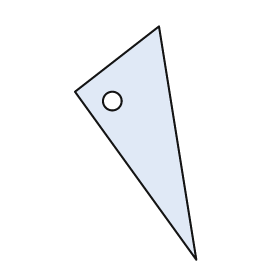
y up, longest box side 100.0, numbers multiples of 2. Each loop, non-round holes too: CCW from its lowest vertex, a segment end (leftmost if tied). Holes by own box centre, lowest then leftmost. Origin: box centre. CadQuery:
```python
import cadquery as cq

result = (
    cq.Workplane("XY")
    .moveTo(26.0, -50.0)
    .lineTo(10.0, 50.0)
    .lineTo(-26.0, 22.0)
    .close()
    .moveTo(-10.0, 18.0)
    .circle(4.0)
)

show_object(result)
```